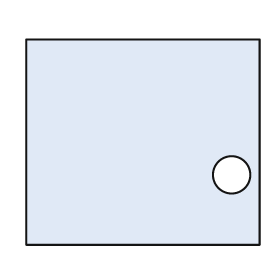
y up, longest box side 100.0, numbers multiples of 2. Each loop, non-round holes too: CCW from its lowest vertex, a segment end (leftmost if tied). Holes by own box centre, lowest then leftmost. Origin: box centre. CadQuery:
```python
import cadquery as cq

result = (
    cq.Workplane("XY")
    .moveTo(-50.0, -44.0)
    .lineTo(50.0, -44.0)
    .lineTo(50.0, 44.0)
    .lineTo(-50.0, 44.0)
    .close()
    .moveTo(38.0, -14.0)
    .circle(8.0)
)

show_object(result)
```